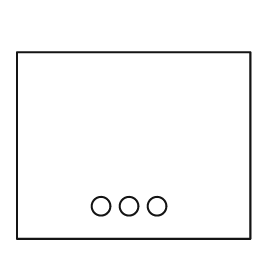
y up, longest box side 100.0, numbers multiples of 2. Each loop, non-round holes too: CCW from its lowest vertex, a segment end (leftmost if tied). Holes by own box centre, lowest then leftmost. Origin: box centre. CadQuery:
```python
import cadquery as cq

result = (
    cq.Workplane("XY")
    .moveTo(-50.0, -40.0)
    .lineTo(50.0, -40.0)
    .lineTo(50.0, 40.0)
    .lineTo(-50.0, 40.0)
    .close()
    .moveTo(-14.0, -26.0)
    .circle(4.0)
    .moveTo(-2.0, -26.0)
    .circle(4.0)
    .moveTo(10.0, -26.0)
    .circle(4.0)
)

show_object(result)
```